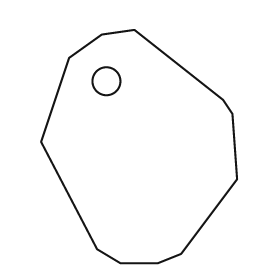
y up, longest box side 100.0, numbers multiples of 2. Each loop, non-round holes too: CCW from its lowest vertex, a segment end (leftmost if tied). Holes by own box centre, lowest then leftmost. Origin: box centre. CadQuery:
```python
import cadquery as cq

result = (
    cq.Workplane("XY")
    .moveTo(-8.0, -50.0)
    .lineTo(8.0, -50.0)
    .lineTo(18.0, -46.0)
    .lineTo(42.0, -14.0)
    .lineTo(40.0, 14.0)
    .lineTo(36.0, 20.0)
    .lineTo(-2.0, 50.0)
    .lineTo(-16.0, 48.0)
    .lineTo(-30.0, 38.0)
    .lineTo(-42.0, 2.0)
    .lineTo(-18.0, -44.0)
    .close()
    .moveTo(-14.0, 28.0)
    .circle(6.0)
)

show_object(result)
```